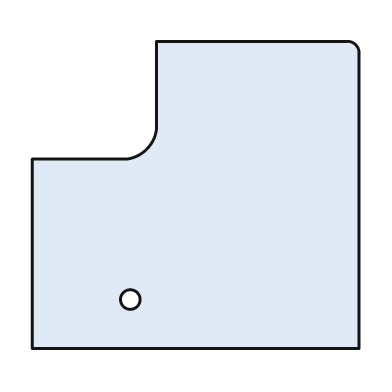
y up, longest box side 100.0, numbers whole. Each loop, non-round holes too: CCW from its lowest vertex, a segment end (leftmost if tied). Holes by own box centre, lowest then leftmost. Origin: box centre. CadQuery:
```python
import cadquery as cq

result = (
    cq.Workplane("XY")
    .moveTo(-50.0, -47.0)
    .lineTo(50.0, -47.0)
    .lineTo(50.0, 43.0)
    .threePointArc((49.0, 46.0), (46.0, 47.0))
    .lineTo(-12.0, 47.0)
    .lineTo(-12.0, 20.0)
    .threePointArc((-15.0, 14.0), (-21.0, 11.0))
    .lineTo(-50.0, 11.0)
    .close()
    .moveTo(-20.0, -32.0)
    .circle(3.0)
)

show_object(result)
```